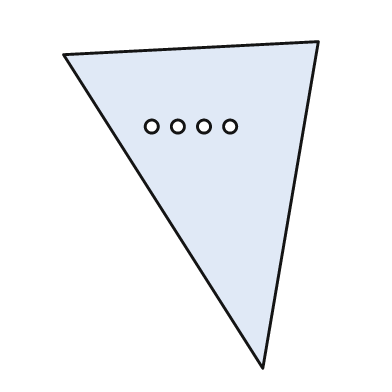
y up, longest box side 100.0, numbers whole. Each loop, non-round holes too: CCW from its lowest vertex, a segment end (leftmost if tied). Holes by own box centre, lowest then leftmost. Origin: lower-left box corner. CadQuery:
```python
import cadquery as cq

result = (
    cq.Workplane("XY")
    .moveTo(61.0, 0.0)
    .lineTo(78.0, 100.0)
    .lineTo(0.0, 96.0)
    .close()
    .moveTo(27.0, 74.0)
    .circle(2.0)
    .moveTo(35.0, 74.0)
    .circle(2.0)
    .moveTo(43.0, 74.0)
    .circle(2.0)
    .moveTo(51.0, 74.0)
    .circle(2.0)
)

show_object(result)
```